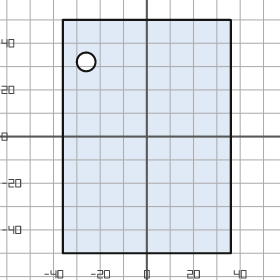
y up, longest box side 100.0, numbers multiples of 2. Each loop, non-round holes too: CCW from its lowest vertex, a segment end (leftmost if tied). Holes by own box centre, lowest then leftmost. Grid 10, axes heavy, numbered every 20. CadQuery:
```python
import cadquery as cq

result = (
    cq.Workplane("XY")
    .moveTo(-36.0, -50.0)
    .lineTo(36.0, -50.0)
    .lineTo(36.0, 50.0)
    .lineTo(-36.0, 50.0)
    .close()
    .moveTo(-26.0, 32.0)
    .circle(4.0)
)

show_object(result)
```